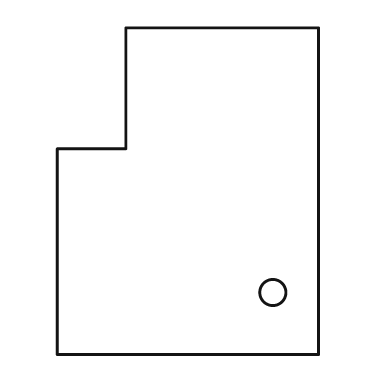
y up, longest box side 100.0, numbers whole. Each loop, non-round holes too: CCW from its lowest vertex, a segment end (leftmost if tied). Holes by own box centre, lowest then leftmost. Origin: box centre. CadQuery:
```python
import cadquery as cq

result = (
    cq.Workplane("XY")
    .moveTo(-40.0, -50.0)
    .lineTo(40.0, -50.0)
    .lineTo(40.0, 50.0)
    .lineTo(-19.0, 50.0)
    .lineTo(-19.0, 13.0)
    .lineTo(-40.0, 13.0)
    .close()
    .moveTo(26.0, -31.0)
    .circle(4.0)
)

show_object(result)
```